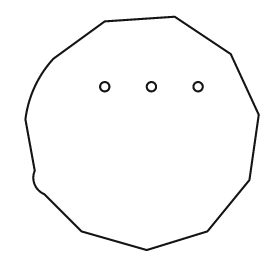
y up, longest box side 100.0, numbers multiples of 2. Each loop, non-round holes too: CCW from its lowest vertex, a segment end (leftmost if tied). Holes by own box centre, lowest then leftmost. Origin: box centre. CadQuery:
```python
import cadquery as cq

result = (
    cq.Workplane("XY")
    .moveTo(2.0, -50.0)
    .lineTo(28.0, -42.0)
    .lineTo(46.0, -20.0)
    .lineTo(50.0, 8.0)
    .lineTo(38.0, 34.0)
    .lineTo(14.0, 50.0)
    .lineTo(-16.0, 48.0)
    .lineTo(-38.0, 32.0)
    .threePointArc((-46.0, 20.0), (-50.0, 6.0))
    .lineTo(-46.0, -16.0)
    .threePointArc((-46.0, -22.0), (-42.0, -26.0))
    .lineTo(-26.0, -42.0)
    .close()
    .moveTo(-16.0, 20.0)
    .circle(2.0)
    .moveTo(4.0, 20.0)
    .circle(2.0)
    .moveTo(24.0, 20.0)
    .circle(2.0)
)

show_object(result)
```